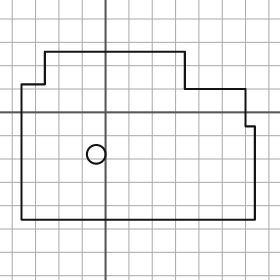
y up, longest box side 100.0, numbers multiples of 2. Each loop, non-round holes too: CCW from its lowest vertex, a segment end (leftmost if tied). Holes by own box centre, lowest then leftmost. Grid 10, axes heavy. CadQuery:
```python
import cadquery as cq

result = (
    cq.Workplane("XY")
    .moveTo(-36.0, -46.0)
    .lineTo(64.0, -46.0)
    .lineTo(64.0, -6.0)
    .lineTo(60.0, -6.0)
    .lineTo(60.0, 10.0)
    .lineTo(34.0, 10.0)
    .lineTo(34.0, 26.0)
    .lineTo(-26.0, 26.0)
    .lineTo(-26.0, 12.0)
    .lineTo(-36.0, 12.0)
    .close()
    .moveTo(-4.0, -18.0)
    .circle(4.0)
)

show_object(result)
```